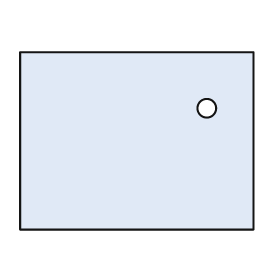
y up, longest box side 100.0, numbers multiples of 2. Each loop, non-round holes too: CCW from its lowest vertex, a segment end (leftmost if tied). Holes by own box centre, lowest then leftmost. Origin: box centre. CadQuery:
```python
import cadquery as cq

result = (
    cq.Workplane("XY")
    .moveTo(-50.0, -38.0)
    .lineTo(50.0, -38.0)
    .lineTo(50.0, 38.0)
    .lineTo(-50.0, 38.0)
    .close()
    .moveTo(30.0, 14.0)
    .circle(4.0)
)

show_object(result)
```